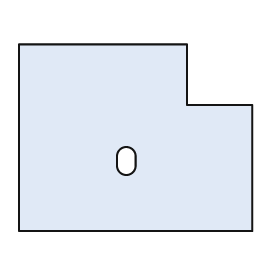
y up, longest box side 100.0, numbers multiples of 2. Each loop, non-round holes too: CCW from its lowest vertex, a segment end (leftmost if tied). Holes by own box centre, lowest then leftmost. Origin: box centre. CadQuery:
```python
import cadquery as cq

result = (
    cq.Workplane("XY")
    .moveTo(-50.0, -40.0)
    .lineTo(50.0, -40.0)
    .lineTo(50.0, 14.0)
    .lineTo(22.0, 14.0)
    .lineTo(22.0, 40.0)
    .lineTo(-50.0, 40.0)
    .close()
    .moveTo(-8.0, -12.0)
    .threePointArc((-4.0, -16.0), (0.0, -12.0))
    .lineTo(0.0, -8.0)
    .threePointArc((-4.0, -4.0), (-8.0, -8.0))
    .close()
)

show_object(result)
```